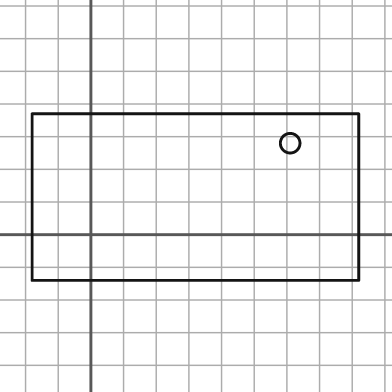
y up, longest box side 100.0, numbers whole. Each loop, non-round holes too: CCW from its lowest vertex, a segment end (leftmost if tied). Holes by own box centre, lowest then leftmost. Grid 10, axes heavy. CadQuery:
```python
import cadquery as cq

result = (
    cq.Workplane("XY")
    .moveTo(-18.0, -14.0)
    .lineTo(82.0, -14.0)
    .lineTo(82.0, 37.0)
    .lineTo(-18.0, 37.0)
    .close()
    .moveTo(61.0, 28.0)
    .circle(3.0)
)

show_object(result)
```